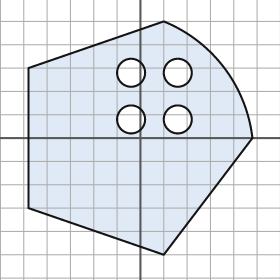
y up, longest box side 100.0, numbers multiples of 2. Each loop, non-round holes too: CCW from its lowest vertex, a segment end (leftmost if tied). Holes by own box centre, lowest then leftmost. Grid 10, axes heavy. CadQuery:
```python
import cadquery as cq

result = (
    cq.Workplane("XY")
    .moveTo(10.0, -50.0)
    .lineTo(48.0, 0.0)
    .threePointArc((36.0, 30.0), (10.0, 50.0))
    .lineTo(-48.0, 30.0)
    .lineTo(-48.0, -30.0)
    .close()
    .moveTo(-4.0, 8.0)
    .circle(6.0)
    .moveTo(16.0, 8.0)
    .circle(6.0)
    .moveTo(-4.0, 28.0)
    .circle(6.0)
    .moveTo(16.0, 28.0)
    .circle(6.0)
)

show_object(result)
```